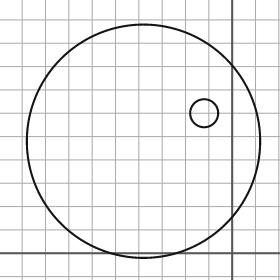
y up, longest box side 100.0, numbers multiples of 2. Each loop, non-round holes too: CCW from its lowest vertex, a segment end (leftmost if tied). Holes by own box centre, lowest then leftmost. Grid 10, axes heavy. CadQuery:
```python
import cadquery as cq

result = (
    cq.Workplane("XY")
    .moveTo(-38.0, 48.0)
    .circle(50.0)
    .moveTo(-12.0, 60.0)
    .circle(6.0)
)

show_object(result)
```